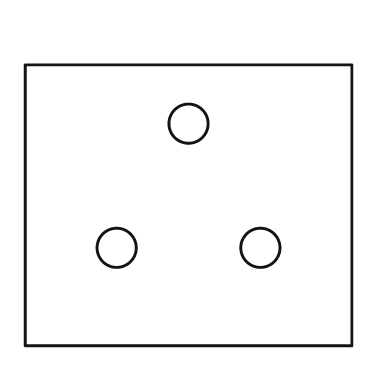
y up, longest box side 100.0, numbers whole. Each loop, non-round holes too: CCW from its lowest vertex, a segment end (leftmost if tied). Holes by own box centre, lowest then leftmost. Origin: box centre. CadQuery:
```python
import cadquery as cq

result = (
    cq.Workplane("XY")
    .moveTo(-50.0, -43.0)
    .lineTo(50.0, -43.0)
    .lineTo(50.0, 43.0)
    .lineTo(-50.0, 43.0)
    .close()
    .moveTo(-22.0, -13.0)
    .circle(6.0)
    .moveTo(22.0, -13.0)
    .circle(6.0)
    .moveTo(0.0, 25.0)
    .circle(6.0)
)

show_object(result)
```